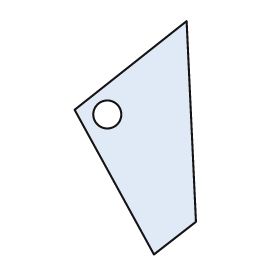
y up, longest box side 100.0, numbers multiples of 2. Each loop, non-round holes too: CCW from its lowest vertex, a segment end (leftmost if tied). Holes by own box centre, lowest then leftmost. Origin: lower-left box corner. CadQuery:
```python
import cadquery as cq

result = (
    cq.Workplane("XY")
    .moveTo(34.0, 0.0)
    .lineTo(52.0, 14.0)
    .lineTo(48.0, 100.0)
    .lineTo(0.0, 62.0)
    .close()
    .moveTo(14.0, 60.0)
    .circle(6.0)
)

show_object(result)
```